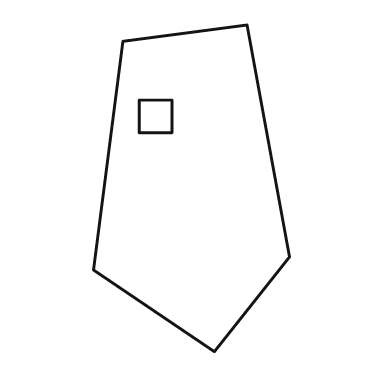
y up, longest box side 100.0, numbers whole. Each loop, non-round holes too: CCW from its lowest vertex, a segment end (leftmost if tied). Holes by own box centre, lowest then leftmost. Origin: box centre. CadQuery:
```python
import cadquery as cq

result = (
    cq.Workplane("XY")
    .moveTo(7.0, -50.0)
    .lineTo(30.0, -21.0)
    .lineTo(17.0, 50.0)
    .lineTo(-21.0, 45.0)
    .lineTo(-30.0, -25.0)
    .close()
    .moveTo(-16.0, 17.0)
    .lineTo(-6.0, 17.0)
    .lineTo(-6.0, 27.0)
    .lineTo(-16.0, 27.0)
    .close()
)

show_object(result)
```